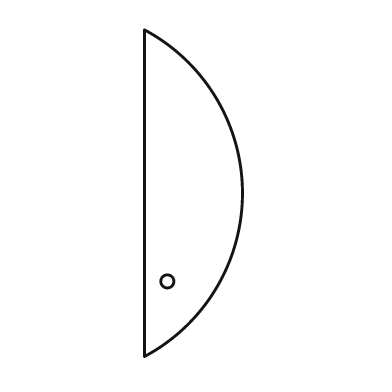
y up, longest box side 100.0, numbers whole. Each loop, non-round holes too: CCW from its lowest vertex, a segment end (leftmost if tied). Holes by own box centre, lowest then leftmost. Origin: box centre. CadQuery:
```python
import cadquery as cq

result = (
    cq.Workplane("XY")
    .moveTo(-15.0, -50.0)
    .threePointArc((15.0, 0.0), (-15.0, 50.0))
    .close()
    .moveTo(-8.0, -27.0)
    .circle(2.0)
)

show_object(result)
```